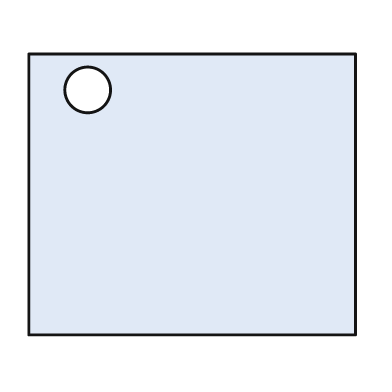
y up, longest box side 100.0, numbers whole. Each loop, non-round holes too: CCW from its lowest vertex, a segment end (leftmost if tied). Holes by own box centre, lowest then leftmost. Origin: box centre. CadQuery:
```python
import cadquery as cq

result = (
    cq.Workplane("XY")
    .moveTo(-50.0, -43.0)
    .lineTo(50.0, -43.0)
    .lineTo(50.0, 43.0)
    .lineTo(-50.0, 43.0)
    .close()
    .moveTo(-32.0, 32.0)
    .circle(7.0)
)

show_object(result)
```